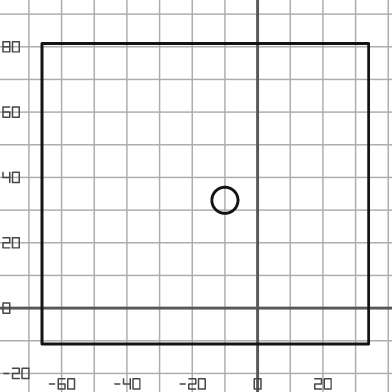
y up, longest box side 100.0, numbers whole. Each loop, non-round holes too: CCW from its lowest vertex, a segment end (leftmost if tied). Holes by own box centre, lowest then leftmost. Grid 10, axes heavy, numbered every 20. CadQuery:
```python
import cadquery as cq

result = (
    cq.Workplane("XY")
    .moveTo(-66.0, -11.0)
    .lineTo(34.0, -11.0)
    .lineTo(34.0, 81.0)
    .lineTo(-66.0, 81.0)
    .close()
    .moveTo(-10.0, 33.0)
    .circle(4.0)
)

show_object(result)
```